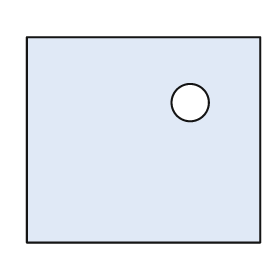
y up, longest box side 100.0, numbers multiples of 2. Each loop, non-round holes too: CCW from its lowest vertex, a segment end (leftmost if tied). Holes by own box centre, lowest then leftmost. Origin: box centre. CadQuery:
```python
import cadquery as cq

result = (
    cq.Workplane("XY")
    .moveTo(-50.0, -44.0)
    .lineTo(50.0, -44.0)
    .lineTo(50.0, 44.0)
    .lineTo(-50.0, 44.0)
    .close()
    .moveTo(20.0, 16.0)
    .circle(8.0)
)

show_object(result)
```